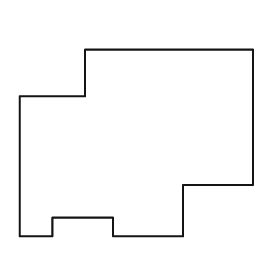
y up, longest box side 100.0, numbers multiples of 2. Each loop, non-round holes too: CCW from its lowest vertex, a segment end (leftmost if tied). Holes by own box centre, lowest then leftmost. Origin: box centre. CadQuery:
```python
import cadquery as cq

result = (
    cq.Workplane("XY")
    .moveTo(-50.0, -40.0)
    .lineTo(-36.0, -40.0)
    .lineTo(-36.0, -32.0)
    .lineTo(-10.0, -32.0)
    .lineTo(-10.0, -40.0)
    .lineTo(20.0, -40.0)
    .lineTo(20.0, -18.0)
    .lineTo(50.0, -18.0)
    .lineTo(50.0, 40.0)
    .lineTo(-22.0, 40.0)
    .lineTo(-22.0, 20.0)
    .lineTo(-50.0, 20.0)
    .close()
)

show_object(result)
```